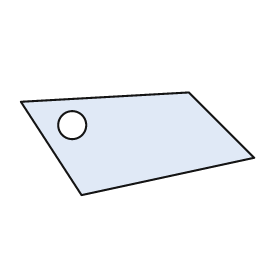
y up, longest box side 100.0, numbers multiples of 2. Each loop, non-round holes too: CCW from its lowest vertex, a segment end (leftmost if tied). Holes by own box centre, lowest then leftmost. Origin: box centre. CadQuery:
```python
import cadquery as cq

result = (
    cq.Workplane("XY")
    .moveTo(-24.0, -22.0)
    .lineTo(50.0, -6.0)
    .lineTo(22.0, 22.0)
    .lineTo(-50.0, 18.0)
    .close()
    .moveTo(-28.0, 8.0)
    .circle(6.0)
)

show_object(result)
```